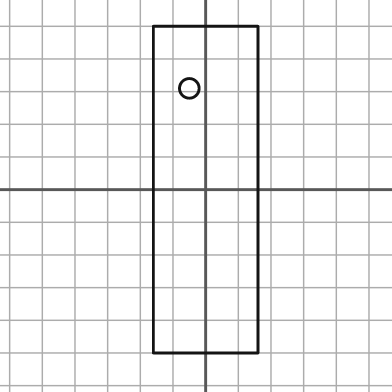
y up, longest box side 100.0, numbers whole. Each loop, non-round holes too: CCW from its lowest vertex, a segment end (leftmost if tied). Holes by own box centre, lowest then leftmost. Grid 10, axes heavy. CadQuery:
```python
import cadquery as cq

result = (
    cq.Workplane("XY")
    .moveTo(-16.0, -50.0)
    .lineTo(16.0, -50.0)
    .lineTo(16.0, 50.0)
    .lineTo(-16.0, 50.0)
    .close()
    .moveTo(-5.0, 31.0)
    .circle(3.0)
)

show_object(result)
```